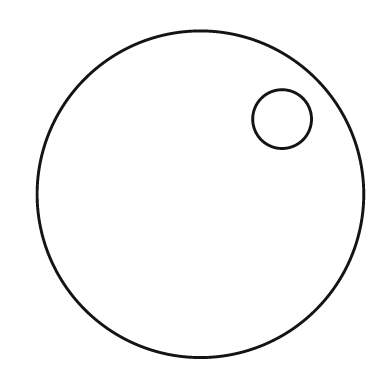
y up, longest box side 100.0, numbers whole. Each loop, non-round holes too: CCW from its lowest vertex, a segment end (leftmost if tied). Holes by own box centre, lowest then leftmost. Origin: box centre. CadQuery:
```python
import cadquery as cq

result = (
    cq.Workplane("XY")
    .moveTo(0.0, 0.0)
    .circle(50.0)
    .moveTo(25.0, 23.0)
    .circle(9.0)
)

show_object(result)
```